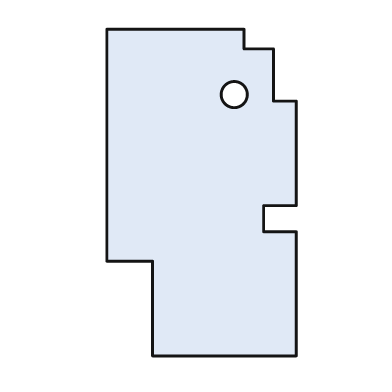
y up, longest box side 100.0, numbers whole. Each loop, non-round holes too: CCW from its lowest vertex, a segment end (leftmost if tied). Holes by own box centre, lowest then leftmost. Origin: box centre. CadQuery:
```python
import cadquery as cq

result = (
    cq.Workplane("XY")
    .moveTo(-15.0, -50.0)
    .lineTo(29.0, -50.0)
    .lineTo(29.0, -12.0)
    .lineTo(19.0, -12.0)
    .lineTo(19.0, -4.0)
    .lineTo(29.0, -4.0)
    .lineTo(29.0, 28.0)
    .lineTo(22.0, 28.0)
    .lineTo(22.0, 44.0)
    .lineTo(13.0, 44.0)
    .lineTo(13.0, 50.0)
    .lineTo(-29.0, 50.0)
    .lineTo(-29.0, -21.0)
    .lineTo(-15.0, -21.0)
    .close()
    .moveTo(10.0, 30.0)
    .circle(4.0)
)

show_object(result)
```